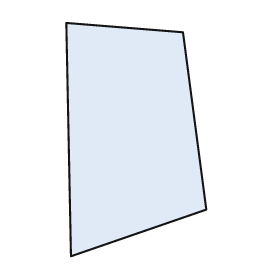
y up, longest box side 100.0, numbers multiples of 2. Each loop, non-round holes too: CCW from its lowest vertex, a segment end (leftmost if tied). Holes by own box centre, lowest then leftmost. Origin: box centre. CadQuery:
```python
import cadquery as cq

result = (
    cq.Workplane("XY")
    .moveTo(-28.0, -50.0)
    .lineTo(30.0, -30.0)
    .lineTo(20.0, 46.0)
    .lineTo(-30.0, 50.0)
    .close()
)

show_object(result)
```